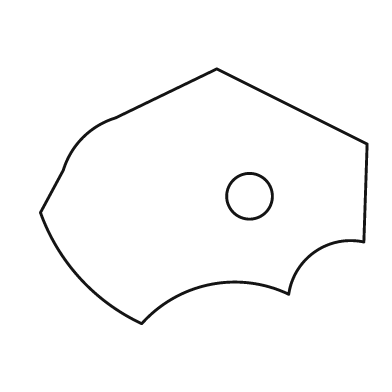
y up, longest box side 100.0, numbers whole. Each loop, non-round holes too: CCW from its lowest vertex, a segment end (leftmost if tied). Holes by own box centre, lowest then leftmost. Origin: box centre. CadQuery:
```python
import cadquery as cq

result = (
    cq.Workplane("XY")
    .moveTo(-19.0, -39.0)
    .threePointArc((2.0, -27.0), (26.0, -30.0))
    .threePointArc((34.0, -17.0), (49.0, -14.0))
    .lineTo(50.0, 16.0)
    .lineTo(4.0, 39.0)
    .lineTo(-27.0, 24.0)
    .threePointArc((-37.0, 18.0), (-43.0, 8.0))
    .lineTo(-50.0, -5.0)
    .threePointArc((-38.0, -25.0), (-19.0, -39.0))
    .close()
    .moveTo(14.0, 0.0)
    .circle(7.0)
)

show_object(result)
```